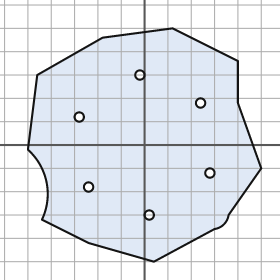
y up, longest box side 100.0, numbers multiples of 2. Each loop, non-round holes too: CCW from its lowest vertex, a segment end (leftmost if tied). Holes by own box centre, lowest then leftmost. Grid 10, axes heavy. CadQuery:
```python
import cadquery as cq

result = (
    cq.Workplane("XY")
    .moveTo(4.0, -50.0)
    .lineTo(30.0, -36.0)
    .threePointArc((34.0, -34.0), (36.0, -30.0))
    .lineTo(50.0, -10.0)
    .lineTo(40.0, 18.0)
    .lineTo(40.0, 36.0)
    .lineTo(12.0, 50.0)
    .lineTo(-18.0, 46.0)
    .lineTo(-46.0, 30.0)
    .lineTo(-50.0, -2.0)
    .threePointArc((-42.0, -16.0), (-44.0, -32.0))
    .lineTo(-24.0, -42.0)
    .close()
    .moveTo(2.0, -30.0)
    .circle(2.0)
    .moveTo(-24.0, -18.0)
    .circle(2.0)
    .moveTo(28.0, -12.0)
    .circle(2.0)
    .moveTo(-28.0, 12.0)
    .circle(2.0)
    .moveTo(24.0, 18.0)
    .circle(2.0)
    .moveTo(-2.0, 30.0)
    .circle(2.0)
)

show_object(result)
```